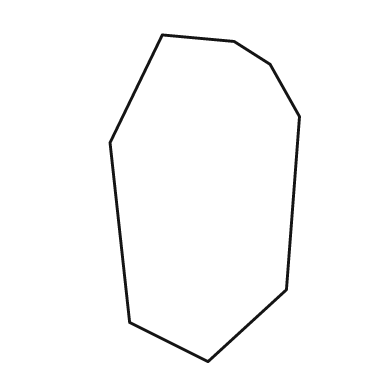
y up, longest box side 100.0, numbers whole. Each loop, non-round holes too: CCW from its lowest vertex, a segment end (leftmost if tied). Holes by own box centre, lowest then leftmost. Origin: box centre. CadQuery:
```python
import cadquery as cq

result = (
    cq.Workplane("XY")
    .moveTo(1.0, -50.0)
    .lineTo(25.0, -28.0)
    .lineTo(29.0, 25.0)
    .lineTo(20.0, 41.0)
    .lineTo(9.0, 48.0)
    .lineTo(-13.0, 50.0)
    .lineTo(-29.0, 17.0)
    .lineTo(-23.0, -38.0)
    .close()
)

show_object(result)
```